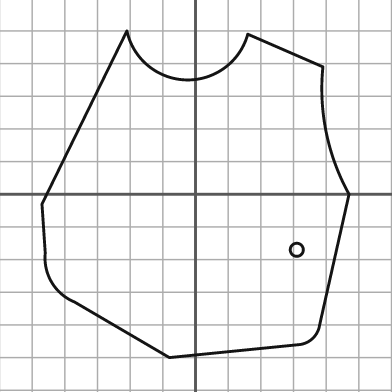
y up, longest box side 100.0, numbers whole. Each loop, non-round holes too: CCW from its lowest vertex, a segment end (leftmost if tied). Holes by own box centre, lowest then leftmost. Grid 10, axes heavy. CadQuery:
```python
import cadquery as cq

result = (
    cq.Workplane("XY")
    .moveTo(-8.0, -50.0)
    .lineTo(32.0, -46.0)
    .threePointArc((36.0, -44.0), (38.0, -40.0))
    .lineTo(47.0, 0.0)
    .threePointArc((40.0, 19.0), (39.0, 39.0))
    .lineTo(16.0, 49.0)
    .threePointArc((-3.0, 35.0), (-21.0, 50.0))
    .lineTo(-47.0, -3.0)
    .lineTo(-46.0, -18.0)
    .threePointArc((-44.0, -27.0), (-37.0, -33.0))
    .close()
    .moveTo(31.0, -17.0)
    .circle(2.0)
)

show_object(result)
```